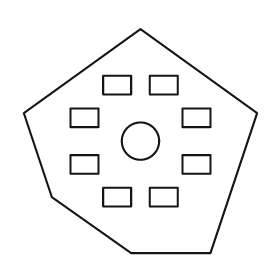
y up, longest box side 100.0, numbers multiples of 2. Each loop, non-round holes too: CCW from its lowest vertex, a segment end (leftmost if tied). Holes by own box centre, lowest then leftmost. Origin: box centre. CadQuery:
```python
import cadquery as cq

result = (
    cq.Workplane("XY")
    .moveTo(-4.0, -48.0)
    .lineTo(30.0, -48.0)
    .lineTo(50.0, 12.0)
    .lineTo(0.0, 48.0)
    .lineTo(-50.0, 12.0)
    .lineTo(-38.0, -24.0)
    .close()
    .moveTo(-16.0, -28.0)
    .lineTo(-4.0, -28.0)
    .lineTo(-4.0, -20.0)
    .lineTo(-16.0, -20.0)
    .close()
    .moveTo(4.0, -28.0)
    .lineTo(16.0, -28.0)
    .lineTo(16.0, -20.0)
    .lineTo(4.0, -20.0)
    .close()
    .moveTo(-30.0, -14.0)
    .lineTo(-18.0, -14.0)
    .lineTo(-18.0, -6.0)
    .lineTo(-30.0, -6.0)
    .close()
    .moveTo(18.0, -14.0)
    .lineTo(30.0, -14.0)
    .lineTo(30.0, -6.0)
    .lineTo(18.0, -6.0)
    .close()
    .moveTo(0.0, 0.0)
    .circle(8.0)
    .moveTo(-30.0, 6.0)
    .lineTo(-18.0, 6.0)
    .lineTo(-18.0, 14.0)
    .lineTo(-30.0, 14.0)
    .close()
    .moveTo(18.0, 6.0)
    .lineTo(30.0, 6.0)
    .lineTo(30.0, 14.0)
    .lineTo(18.0, 14.0)
    .close()
    .moveTo(-16.0, 20.0)
    .lineTo(-4.0, 20.0)
    .lineTo(-4.0, 28.0)
    .lineTo(-16.0, 28.0)
    .close()
    .moveTo(4.0, 20.0)
    .lineTo(16.0, 20.0)
    .lineTo(16.0, 28.0)
    .lineTo(4.0, 28.0)
    .close()
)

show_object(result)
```